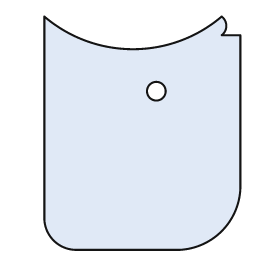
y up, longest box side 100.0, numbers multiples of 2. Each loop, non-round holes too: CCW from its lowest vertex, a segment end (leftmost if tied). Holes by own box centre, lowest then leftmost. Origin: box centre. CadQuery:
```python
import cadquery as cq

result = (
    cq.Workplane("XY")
    .moveTo(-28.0, -50.0)
    .lineTo(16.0, -50.0)
    .threePointArc((34.0, -42.0), (42.0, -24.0))
    .lineTo(42.0, 42.0)
    .lineTo(34.0, 42.0)
    .threePointArc((36.0, 46.0), (34.0, 50.0))
    .threePointArc((-4.0, 36.0), (-42.0, 50.0))
    .lineTo(-42.0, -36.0)
    .threePointArc((-38.0, -46.0), (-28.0, -50.0))
    .close()
    .moveTo(6.0, 18.0)
    .circle(4.0)
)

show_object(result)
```